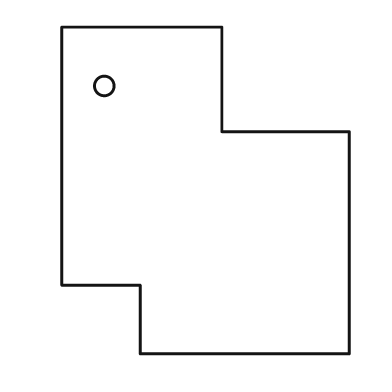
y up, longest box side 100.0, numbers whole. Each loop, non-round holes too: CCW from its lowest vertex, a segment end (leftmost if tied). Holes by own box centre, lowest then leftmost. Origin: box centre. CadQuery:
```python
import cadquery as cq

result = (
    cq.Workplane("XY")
    .moveTo(-20.0, -50.0)
    .lineTo(44.0, -50.0)
    .lineTo(44.0, 18.0)
    .lineTo(5.0, 18.0)
    .lineTo(5.0, 50.0)
    .lineTo(-44.0, 50.0)
    .lineTo(-44.0, -29.0)
    .lineTo(-20.0, -29.0)
    .close()
    .moveTo(-31.0, 32.0)
    .circle(3.0)
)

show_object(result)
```